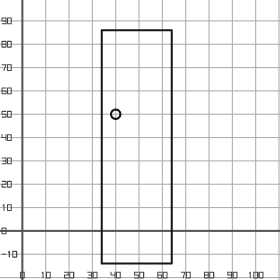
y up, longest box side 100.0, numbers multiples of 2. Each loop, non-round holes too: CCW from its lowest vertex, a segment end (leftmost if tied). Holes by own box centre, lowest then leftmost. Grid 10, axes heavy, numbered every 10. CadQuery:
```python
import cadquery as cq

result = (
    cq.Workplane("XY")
    .moveTo(34.0, -14.0)
    .lineTo(64.0, -14.0)
    .lineTo(64.0, 86.0)
    .lineTo(34.0, 86.0)
    .close()
    .moveTo(40.0, 50.0)
    .circle(2.0)
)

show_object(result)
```